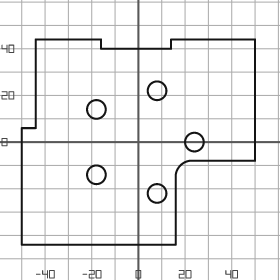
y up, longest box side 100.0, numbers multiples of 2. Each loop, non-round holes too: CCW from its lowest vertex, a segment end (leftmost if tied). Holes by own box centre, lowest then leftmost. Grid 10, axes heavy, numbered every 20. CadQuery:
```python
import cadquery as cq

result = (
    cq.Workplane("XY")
    .moveTo(-50.0, -44.0)
    .lineTo(16.0, -44.0)
    .lineTo(16.0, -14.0)
    .threePointArc((18.0, -10.0), (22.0, -8.0))
    .lineTo(50.0, -8.0)
    .lineTo(50.0, 44.0)
    .lineTo(14.0, 44.0)
    .lineTo(14.0, 40.0)
    .lineTo(-16.0, 40.0)
    .lineTo(-16.0, 44.0)
    .lineTo(-44.0, 44.0)
    .lineTo(-44.0, 6.0)
    .lineTo(-50.0, 6.0)
    .close()
    .moveTo(8.0, -22.0)
    .circle(4.0)
    .moveTo(-18.0, -14.0)
    .circle(4.0)
    .moveTo(24.0, 0.0)
    .circle(4.0)
    .moveTo(-18.0, 14.0)
    .circle(4.0)
    .moveTo(8.0, 22.0)
    .circle(4.0)
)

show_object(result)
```